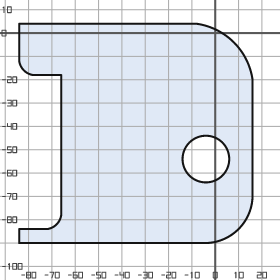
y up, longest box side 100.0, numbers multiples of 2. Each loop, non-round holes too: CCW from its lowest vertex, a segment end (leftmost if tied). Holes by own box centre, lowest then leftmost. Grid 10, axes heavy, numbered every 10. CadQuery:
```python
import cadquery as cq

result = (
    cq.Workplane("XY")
    .moveTo(-84.0, -90.0)
    .lineTo(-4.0, -90.0)
    .threePointArc((10.0, -84.0), (16.0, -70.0))
    .lineTo(16.0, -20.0)
    .threePointArc((8.0, -4.0), (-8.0, 4.0))
    .lineTo(-84.0, 4.0)
    .lineTo(-84.0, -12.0)
    .threePointArc((-82.0, -16.0), (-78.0, -18.0))
    .lineTo(-66.0, -18.0)
    .lineTo(-66.0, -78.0)
    .threePointArc((-68.0, -82.0), (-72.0, -84.0))
    .lineTo(-84.0, -84.0)
    .close()
    .moveTo(-4.0, -54.0)
    .circle(10.0)
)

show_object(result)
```